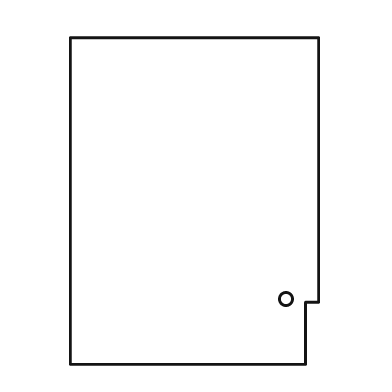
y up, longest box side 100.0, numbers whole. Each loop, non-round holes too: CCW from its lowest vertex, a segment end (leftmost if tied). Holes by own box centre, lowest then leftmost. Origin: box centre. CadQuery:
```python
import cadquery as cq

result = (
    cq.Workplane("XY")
    .moveTo(-38.0, -50.0)
    .lineTo(34.0, -50.0)
    .lineTo(34.0, -31.0)
    .lineTo(38.0, -31.0)
    .lineTo(38.0, 50.0)
    .lineTo(-38.0, 50.0)
    .close()
    .moveTo(28.0, -30.0)
    .circle(2.0)
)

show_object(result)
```